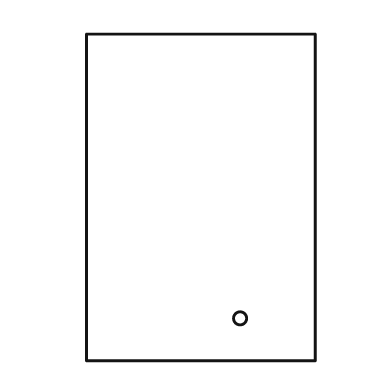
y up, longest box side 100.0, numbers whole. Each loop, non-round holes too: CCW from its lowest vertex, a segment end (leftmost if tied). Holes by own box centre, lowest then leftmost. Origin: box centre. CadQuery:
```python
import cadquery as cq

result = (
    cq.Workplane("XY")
    .moveTo(-35.0, -50.0)
    .lineTo(35.0, -50.0)
    .lineTo(35.0, 50.0)
    .lineTo(-35.0, 50.0)
    .close()
    .moveTo(12.0, -37.0)
    .circle(2.0)
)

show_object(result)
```